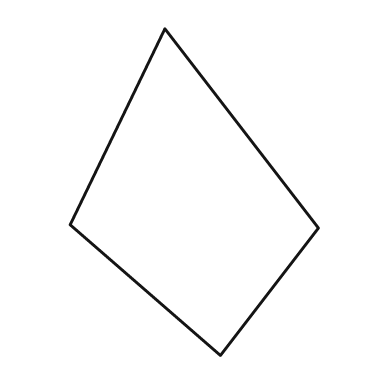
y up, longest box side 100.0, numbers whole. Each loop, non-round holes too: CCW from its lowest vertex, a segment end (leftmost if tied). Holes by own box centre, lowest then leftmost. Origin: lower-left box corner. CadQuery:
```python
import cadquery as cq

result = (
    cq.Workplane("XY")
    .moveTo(46.0, 0.0)
    .lineTo(76.0, 39.0)
    .lineTo(29.0, 100.0)
    .lineTo(0.0, 40.0)
    .close()
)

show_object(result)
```